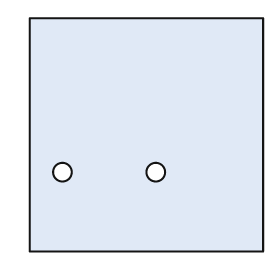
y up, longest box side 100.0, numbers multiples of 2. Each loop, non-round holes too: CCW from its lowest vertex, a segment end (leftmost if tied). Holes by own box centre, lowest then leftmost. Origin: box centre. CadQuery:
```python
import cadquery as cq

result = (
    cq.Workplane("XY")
    .moveTo(-50.0, -50.0)
    .lineTo(50.0, -50.0)
    .lineTo(50.0, 50.0)
    .lineTo(-50.0, 50.0)
    .close()
    .moveTo(-36.0, -16.0)
    .circle(4.0)
    .moveTo(4.0, -16.0)
    .circle(4.0)
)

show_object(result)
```